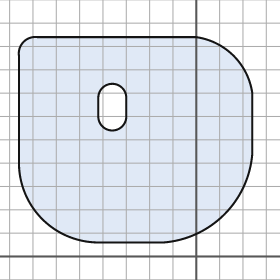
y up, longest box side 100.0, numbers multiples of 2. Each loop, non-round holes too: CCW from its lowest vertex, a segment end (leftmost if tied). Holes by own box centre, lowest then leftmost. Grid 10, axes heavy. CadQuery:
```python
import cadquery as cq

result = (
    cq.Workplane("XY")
    .moveTo(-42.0, 6.0)
    .lineTo(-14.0, 6.0)
    .threePointArc((12.0, 18.0), (24.0, 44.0))
    .lineTo(24.0, 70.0)
    .threePointArc((16.0, 86.0), (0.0, 94.0))
    .lineTo(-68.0, 94.0)
    .threePointArc((-74.0, 92.0), (-76.0, 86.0))
    .lineTo(-76.0, 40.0)
    .threePointArc((-66.0, 16.0), (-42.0, 6.0))
    .close()
    .moveTo(-42.0, 60.0)
    .threePointArc((-36.0, 54.0), (-30.0, 60.0))
    .lineTo(-30.0, 68.0)
    .threePointArc((-36.0, 74.0), (-42.0, 68.0))
    .close()
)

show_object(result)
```